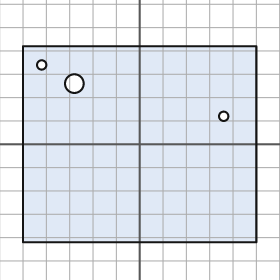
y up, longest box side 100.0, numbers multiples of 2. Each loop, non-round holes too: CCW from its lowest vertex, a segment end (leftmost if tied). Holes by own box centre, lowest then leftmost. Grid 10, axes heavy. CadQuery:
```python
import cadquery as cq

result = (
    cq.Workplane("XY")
    .moveTo(-50.0, -42.0)
    .lineTo(50.0, -42.0)
    .lineTo(50.0, 42.0)
    .lineTo(-50.0, 42.0)
    .close()
    .moveTo(36.0, 12.0)
    .circle(2.0)
    .moveTo(-28.0, 26.0)
    .circle(4.0)
    .moveTo(-42.0, 34.0)
    .circle(2.0)
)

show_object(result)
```